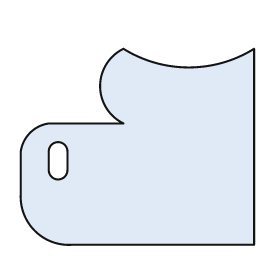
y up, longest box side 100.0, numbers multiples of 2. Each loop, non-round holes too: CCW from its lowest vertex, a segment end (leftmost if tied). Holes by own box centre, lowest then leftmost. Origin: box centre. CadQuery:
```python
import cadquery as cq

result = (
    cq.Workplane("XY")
    .moveTo(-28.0, -42.0)
    .lineTo(50.0, -42.0)
    .lineTo(50.0, 42.0)
    .threePointArc((22.0, 34.0), (-6.0, 42.0))
    .threePointArc((-16.0, 26.0), (-6.0, 10.0))
    .lineTo(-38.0, 10.0)
    .threePointArc((-46.0, 6.0), (-50.0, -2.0))
    .lineTo(-50.0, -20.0)
    .threePointArc((-44.0, -36.0), (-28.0, -42.0))
    .close()
    .moveTo(-38.0, -10.0)
    .threePointArc((-34.0, -14.0), (-30.0, -10.0))
    .lineTo(-30.0, -2.0)
    .threePointArc((-34.0, 2.0), (-38.0, -2.0))
    .close()
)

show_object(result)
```